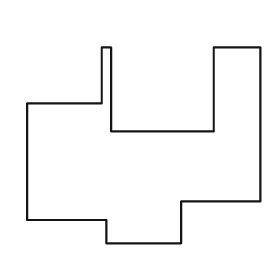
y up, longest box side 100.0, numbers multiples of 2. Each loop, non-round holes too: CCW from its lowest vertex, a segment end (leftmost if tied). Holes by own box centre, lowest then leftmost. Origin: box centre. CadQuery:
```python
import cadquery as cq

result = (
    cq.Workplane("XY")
    .moveTo(-16.0, -42.0)
    .lineTo(16.0, -42.0)
    .lineTo(16.0, -24.0)
    .lineTo(50.0, -24.0)
    .lineTo(50.0, 42.0)
    .lineTo(30.0, 42.0)
    .lineTo(30.0, 6.0)
    .lineTo(-14.0, 6.0)
    .lineTo(-14.0, 42.0)
    .lineTo(-18.0, 42.0)
    .lineTo(-18.0, 18.0)
    .lineTo(-50.0, 18.0)
    .lineTo(-50.0, -32.0)
    .lineTo(-16.0, -32.0)
    .close()
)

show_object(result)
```